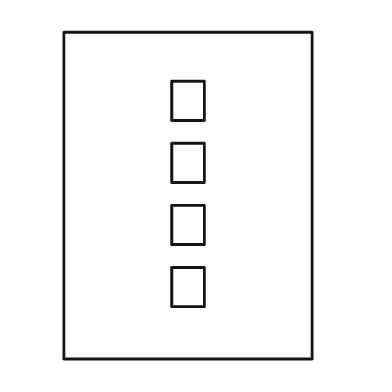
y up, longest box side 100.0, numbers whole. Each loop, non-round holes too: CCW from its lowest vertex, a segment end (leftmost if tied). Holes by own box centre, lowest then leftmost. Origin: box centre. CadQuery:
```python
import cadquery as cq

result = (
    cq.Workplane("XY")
    .moveTo(-38.0, -50.0)
    .lineTo(38.0, -50.0)
    .lineTo(38.0, 50.0)
    .lineTo(-38.0, 50.0)
    .close()
    .moveTo(-5.0, -34.0)
    .lineTo(5.0, -34.0)
    .lineTo(5.0, -22.0)
    .lineTo(-5.0, -22.0)
    .close()
    .moveTo(-5.0, -15.0)
    .lineTo(5.0, -15.0)
    .lineTo(5.0, -3.0)
    .lineTo(-5.0, -3.0)
    .close()
    .moveTo(-5.0, 4.0)
    .lineTo(5.0, 4.0)
    .lineTo(5.0, 16.0)
    .lineTo(-5.0, 16.0)
    .close()
    .moveTo(-5.0, 23.0)
    .lineTo(5.0, 23.0)
    .lineTo(5.0, 35.0)
    .lineTo(-5.0, 35.0)
    .close()
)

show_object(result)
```